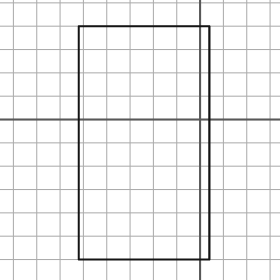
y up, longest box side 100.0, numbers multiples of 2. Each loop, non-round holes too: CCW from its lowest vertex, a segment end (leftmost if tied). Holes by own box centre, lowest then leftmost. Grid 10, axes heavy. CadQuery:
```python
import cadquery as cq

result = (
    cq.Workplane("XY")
    .moveTo(-52.0, -60.0)
    .lineTo(4.0, -60.0)
    .lineTo(4.0, 40.0)
    .lineTo(-52.0, 40.0)
    .close()
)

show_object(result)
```